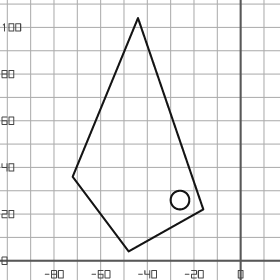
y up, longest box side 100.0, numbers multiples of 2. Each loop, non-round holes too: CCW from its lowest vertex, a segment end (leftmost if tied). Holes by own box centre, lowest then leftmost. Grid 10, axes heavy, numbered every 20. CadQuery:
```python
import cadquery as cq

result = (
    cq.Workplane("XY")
    .moveTo(-48.0, 4.0)
    .lineTo(-16.0, 22.0)
    .lineTo(-44.0, 104.0)
    .lineTo(-72.0, 36.0)
    .close()
    .moveTo(-26.0, 26.0)
    .circle(4.0)
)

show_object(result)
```